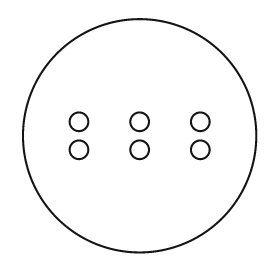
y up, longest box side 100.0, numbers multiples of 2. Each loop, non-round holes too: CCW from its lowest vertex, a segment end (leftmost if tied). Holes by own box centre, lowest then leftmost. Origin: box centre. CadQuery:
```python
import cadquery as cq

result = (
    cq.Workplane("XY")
    .moveTo(0.0, 0.0)
    .circle(50.0)
    .moveTo(-26.0, -6.0)
    .circle(4.0)
    .moveTo(0.0, -6.0)
    .circle(4.0)
    .moveTo(26.0, -6.0)
    .circle(4.0)
    .moveTo(-26.0, 6.0)
    .circle(4.0)
    .moveTo(0.0, 6.0)
    .circle(4.0)
    .moveTo(26.0, 6.0)
    .circle(4.0)
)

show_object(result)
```